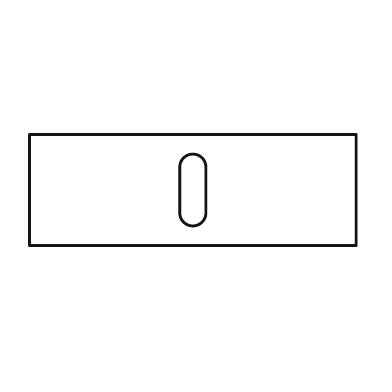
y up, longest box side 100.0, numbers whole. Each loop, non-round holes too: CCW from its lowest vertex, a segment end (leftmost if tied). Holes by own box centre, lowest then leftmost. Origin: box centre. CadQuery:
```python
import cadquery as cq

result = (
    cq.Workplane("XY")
    .moveTo(-50.0, -17.0)
    .lineTo(50.0, -17.0)
    .lineTo(50.0, 17.0)
    .lineTo(-50.0, 17.0)
    .close()
    .moveTo(-4.0, -7.0)
    .threePointArc((0.0, -11.0), (4.0, -7.0))
    .lineTo(4.0, 7.0)
    .threePointArc((0.0, 11.0), (-4.0, 7.0))
    .close()
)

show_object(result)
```